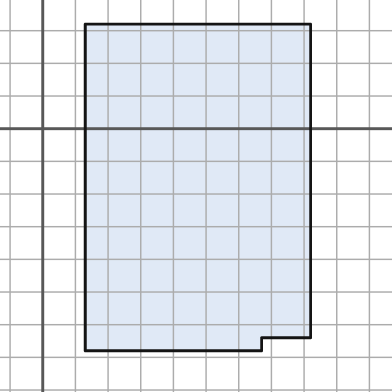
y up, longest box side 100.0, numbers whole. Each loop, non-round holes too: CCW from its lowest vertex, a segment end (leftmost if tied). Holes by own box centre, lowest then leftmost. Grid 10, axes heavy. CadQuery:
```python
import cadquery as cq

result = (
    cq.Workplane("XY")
    .moveTo(13.0, -68.0)
    .lineTo(67.0, -68.0)
    .lineTo(67.0, -64.0)
    .lineTo(82.0, -64.0)
    .lineTo(82.0, 32.0)
    .lineTo(13.0, 32.0)
    .close()
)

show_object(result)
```